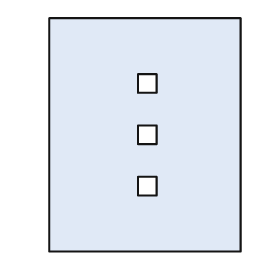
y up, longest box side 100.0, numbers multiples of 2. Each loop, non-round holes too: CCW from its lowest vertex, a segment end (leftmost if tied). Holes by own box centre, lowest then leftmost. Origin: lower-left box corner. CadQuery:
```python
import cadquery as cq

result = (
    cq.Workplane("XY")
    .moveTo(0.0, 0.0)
    .lineTo(82.0, 0.0)
    .lineTo(82.0, 100.0)
    .lineTo(0.0, 100.0)
    .close()
    .moveTo(38.0, 24.0)
    .lineTo(46.0, 24.0)
    .lineTo(46.0, 32.0)
    .lineTo(38.0, 32.0)
    .close()
    .moveTo(38.0, 46.0)
    .lineTo(46.0, 46.0)
    .lineTo(46.0, 54.0)
    .lineTo(38.0, 54.0)
    .close()
    .moveTo(38.0, 68.0)
    .lineTo(46.0, 68.0)
    .lineTo(46.0, 76.0)
    .lineTo(38.0, 76.0)
    .close()
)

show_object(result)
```